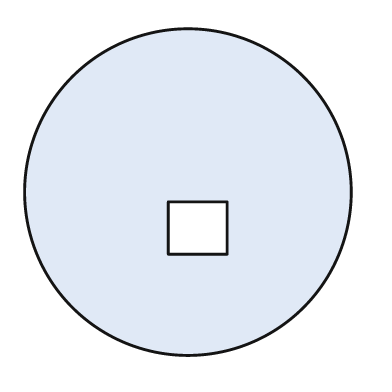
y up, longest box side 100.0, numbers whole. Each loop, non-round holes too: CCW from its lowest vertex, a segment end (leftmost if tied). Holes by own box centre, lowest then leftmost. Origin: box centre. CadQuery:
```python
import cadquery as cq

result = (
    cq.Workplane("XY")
    .moveTo(0.0, 0.0)
    .circle(50.0)
    .moveTo(-6.0, -19.0)
    .lineTo(12.0, -19.0)
    .lineTo(12.0, -3.0)
    .lineTo(-6.0, -3.0)
    .close()
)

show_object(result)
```